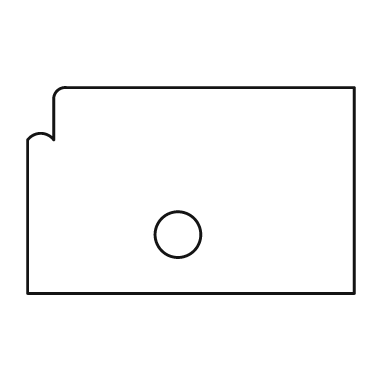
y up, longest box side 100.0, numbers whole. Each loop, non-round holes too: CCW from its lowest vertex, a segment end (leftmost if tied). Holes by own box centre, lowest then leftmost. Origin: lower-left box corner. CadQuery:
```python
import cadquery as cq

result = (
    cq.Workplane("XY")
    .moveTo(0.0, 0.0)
    .lineTo(100.0, 0.0)
    .lineTo(100.0, 63.0)
    .lineTo(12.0, 63.0)
    .threePointArc((9.0, 62.0), (8.0, 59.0))
    .lineTo(8.0, 47.0)
    .threePointArc((4.0, 49.0), (0.0, 47.0))
    .close()
    .moveTo(46.0, 18.0)
    .circle(7.0)
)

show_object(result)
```